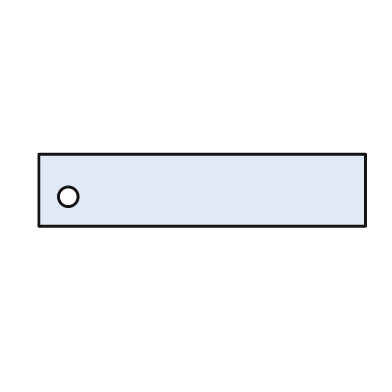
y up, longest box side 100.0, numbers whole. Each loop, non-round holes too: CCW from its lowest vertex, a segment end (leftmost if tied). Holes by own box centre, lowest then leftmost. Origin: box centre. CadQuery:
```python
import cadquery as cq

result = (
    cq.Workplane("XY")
    .moveTo(-50.0, -11.0)
    .lineTo(50.0, -11.0)
    .lineTo(50.0, 11.0)
    .lineTo(-50.0, 11.0)
    .close()
    .moveTo(-41.0, -2.0)
    .circle(3.0)
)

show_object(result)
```